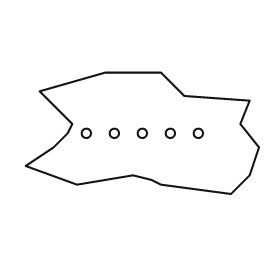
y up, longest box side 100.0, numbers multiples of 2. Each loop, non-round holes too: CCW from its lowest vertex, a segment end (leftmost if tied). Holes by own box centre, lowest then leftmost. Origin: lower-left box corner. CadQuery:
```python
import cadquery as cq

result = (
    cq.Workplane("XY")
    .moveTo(88.0, 0.0)
    .lineTo(96.0, 8.0)
    .lineTo(100.0, 20.0)
    .lineTo(92.0, 30.0)
    .lineTo(96.0, 40.0)
    .lineTo(68.0, 42.0)
    .lineTo(58.0, 52.0)
    .lineTo(34.0, 52.0)
    .lineTo(6.0, 44.0)
    .lineTo(20.0, 30.0)
    .lineTo(18.0, 26.0)
    .lineTo(12.0, 20.0)
    .lineTo(0.0, 12.0)
    .lineTo(22.0, 4.0)
    .lineTo(46.0, 8.0)
    .lineTo(54.0, 6.0)
    .lineTo(58.0, 4.0)
    .close()
    .moveTo(26.0, 26.0)
    .circle(2.0)
    .moveTo(38.0, 26.0)
    .circle(2.0)
    .moveTo(50.0, 26.0)
    .circle(2.0)
    .moveTo(62.0, 26.0)
    .circle(2.0)
    .moveTo(74.0, 26.0)
    .circle(2.0)
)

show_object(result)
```